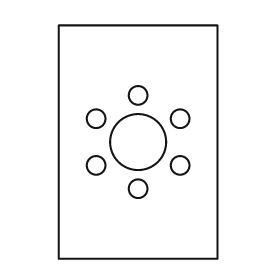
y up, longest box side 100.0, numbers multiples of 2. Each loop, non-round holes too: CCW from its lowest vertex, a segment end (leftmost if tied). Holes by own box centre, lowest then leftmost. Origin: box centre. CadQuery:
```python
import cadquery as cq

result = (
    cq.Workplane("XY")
    .moveTo(-34.0, -50.0)
    .lineTo(34.0, -50.0)
    .lineTo(34.0, 50.0)
    .lineTo(-34.0, 50.0)
    .close()
    .moveTo(0.0, -20.0)
    .circle(4.0)
    .moveTo(-18.0, -10.0)
    .circle(4.0)
    .moveTo(18.0, -10.0)
    .circle(4.0)
    .moveTo(0.0, 0.0)
    .circle(12.0)
    .moveTo(-18.0, 10.0)
    .circle(4.0)
    .moveTo(18.0, 10.0)
    .circle(4.0)
    .moveTo(0.0, 20.0)
    .circle(4.0)
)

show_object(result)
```